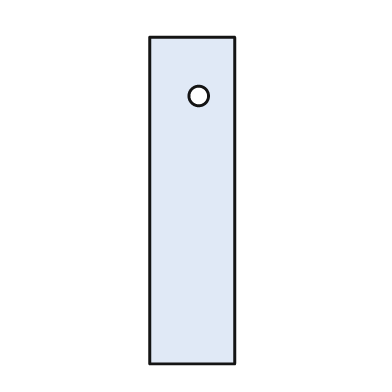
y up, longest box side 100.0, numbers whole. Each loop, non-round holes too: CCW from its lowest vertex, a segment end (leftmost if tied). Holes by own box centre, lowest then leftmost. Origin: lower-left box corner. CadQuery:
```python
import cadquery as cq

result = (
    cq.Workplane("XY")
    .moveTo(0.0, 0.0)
    .lineTo(26.0, 0.0)
    .lineTo(26.0, 100.0)
    .lineTo(0.0, 100.0)
    .close()
    .moveTo(15.0, 82.0)
    .circle(3.0)
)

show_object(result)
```